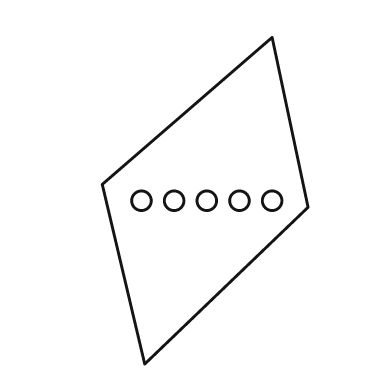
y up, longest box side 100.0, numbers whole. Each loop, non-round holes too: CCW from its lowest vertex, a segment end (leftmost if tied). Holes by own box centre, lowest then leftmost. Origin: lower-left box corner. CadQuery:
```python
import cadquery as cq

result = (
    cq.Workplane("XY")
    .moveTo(13.0, 0.0)
    .lineTo(63.0, 48.0)
    .lineTo(52.0, 100.0)
    .lineTo(0.0, 55.0)
    .close()
    .moveTo(12.0, 50.0)
    .circle(3.0)
    .moveTo(22.0, 50.0)
    .circle(3.0)
    .moveTo(32.0, 50.0)
    .circle(3.0)
    .moveTo(42.0, 50.0)
    .circle(3.0)
    .moveTo(52.0, 50.0)
    .circle(3.0)
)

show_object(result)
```